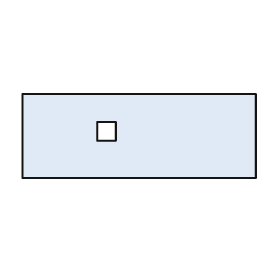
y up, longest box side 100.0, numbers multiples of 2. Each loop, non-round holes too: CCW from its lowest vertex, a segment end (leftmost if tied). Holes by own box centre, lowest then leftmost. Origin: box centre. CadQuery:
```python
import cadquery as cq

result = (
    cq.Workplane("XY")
    .moveTo(-50.0, -18.0)
    .lineTo(50.0, -18.0)
    .lineTo(50.0, 18.0)
    .lineTo(-50.0, 18.0)
    .close()
    .moveTo(-18.0, -2.0)
    .lineTo(-10.0, -2.0)
    .lineTo(-10.0, 6.0)
    .lineTo(-18.0, 6.0)
    .close()
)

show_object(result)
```